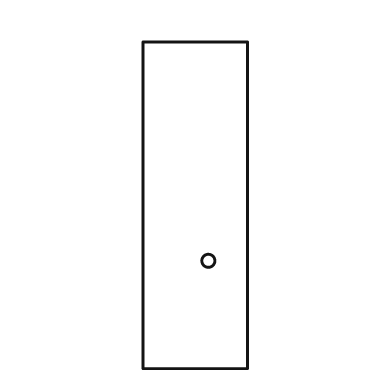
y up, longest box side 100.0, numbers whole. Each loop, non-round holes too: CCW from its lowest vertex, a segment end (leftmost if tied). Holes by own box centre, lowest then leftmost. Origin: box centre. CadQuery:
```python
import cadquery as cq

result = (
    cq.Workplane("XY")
    .moveTo(-16.0, -50.0)
    .lineTo(16.0, -50.0)
    .lineTo(16.0, 50.0)
    .lineTo(-16.0, 50.0)
    .close()
    .moveTo(4.0, -17.0)
    .circle(2.0)
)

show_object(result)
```